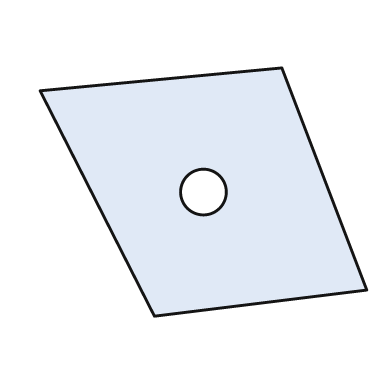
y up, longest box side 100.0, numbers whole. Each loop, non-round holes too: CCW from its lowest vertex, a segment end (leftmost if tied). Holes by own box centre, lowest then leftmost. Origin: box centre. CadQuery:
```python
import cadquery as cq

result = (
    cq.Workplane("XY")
    .moveTo(-15.0, -38.0)
    .lineTo(50.0, -30.0)
    .lineTo(24.0, 38.0)
    .lineTo(-50.0, 31.0)
    .close()
    .moveTo(0.0, 0.0)
    .circle(7.0)
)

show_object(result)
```